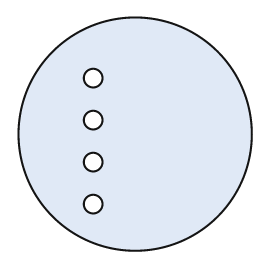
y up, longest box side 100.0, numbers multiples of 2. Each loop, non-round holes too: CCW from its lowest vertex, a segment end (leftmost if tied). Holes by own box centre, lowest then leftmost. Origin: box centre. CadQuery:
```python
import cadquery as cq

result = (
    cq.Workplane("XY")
    .moveTo(0.0, 0.0)
    .circle(50.0)
    .moveTo(-18.0, -30.0)
    .circle(4.0)
    .moveTo(-18.0, -12.0)
    .circle(4.0)
    .moveTo(-18.0, 6.0)
    .circle(4.0)
    .moveTo(-18.0, 24.0)
    .circle(4.0)
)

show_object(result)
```